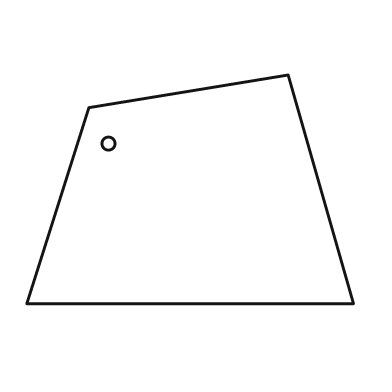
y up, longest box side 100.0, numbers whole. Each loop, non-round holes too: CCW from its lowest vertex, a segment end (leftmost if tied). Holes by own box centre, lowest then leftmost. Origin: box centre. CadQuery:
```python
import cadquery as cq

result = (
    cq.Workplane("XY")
    .moveTo(-50.0, -35.0)
    .lineTo(50.0, -35.0)
    .lineTo(30.0, 35.0)
    .lineTo(-31.0, 25.0)
    .close()
    .moveTo(-25.0, 14.0)
    .circle(2.0)
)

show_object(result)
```